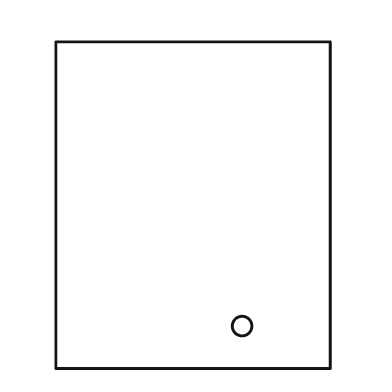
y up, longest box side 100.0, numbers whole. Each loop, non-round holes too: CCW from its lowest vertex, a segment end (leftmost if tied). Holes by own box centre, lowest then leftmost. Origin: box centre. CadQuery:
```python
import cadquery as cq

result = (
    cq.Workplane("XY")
    .moveTo(-42.0, -50.0)
    .lineTo(42.0, -50.0)
    .lineTo(42.0, 50.0)
    .lineTo(-42.0, 50.0)
    .close()
    .moveTo(15.0, -37.0)
    .circle(3.0)
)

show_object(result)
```